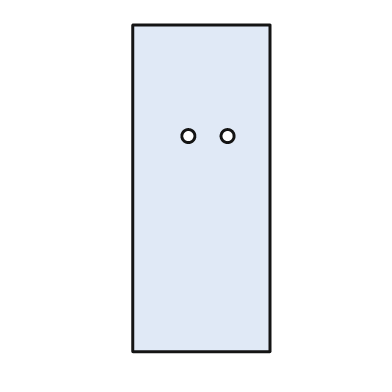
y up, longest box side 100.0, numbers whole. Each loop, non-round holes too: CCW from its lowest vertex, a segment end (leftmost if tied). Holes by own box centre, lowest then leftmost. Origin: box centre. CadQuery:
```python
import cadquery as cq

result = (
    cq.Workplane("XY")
    .moveTo(-21.0, -50.0)
    .lineTo(21.0, -50.0)
    .lineTo(21.0, 50.0)
    .lineTo(-21.0, 50.0)
    .close()
    .moveTo(-4.0, 16.0)
    .circle(2.0)
    .moveTo(8.0, 16.0)
    .circle(2.0)
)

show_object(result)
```